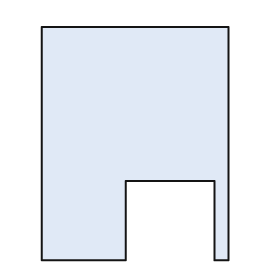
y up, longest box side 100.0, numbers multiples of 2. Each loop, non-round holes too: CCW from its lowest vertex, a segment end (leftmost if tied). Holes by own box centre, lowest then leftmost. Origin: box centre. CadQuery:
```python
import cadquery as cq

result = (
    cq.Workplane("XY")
    .moveTo(-40.0, -50.0)
    .lineTo(-4.0, -50.0)
    .lineTo(-4.0, -16.0)
    .lineTo(34.0, -16.0)
    .lineTo(34.0, -50.0)
    .lineTo(40.0, -50.0)
    .lineTo(40.0, 50.0)
    .lineTo(-40.0, 50.0)
    .close()
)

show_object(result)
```